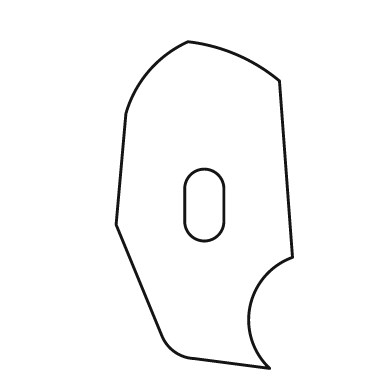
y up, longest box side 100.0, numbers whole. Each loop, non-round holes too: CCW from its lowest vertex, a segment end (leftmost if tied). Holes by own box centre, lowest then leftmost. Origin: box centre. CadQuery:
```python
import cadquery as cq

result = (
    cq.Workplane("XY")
    .moveTo(20.0, -50.0)
    .threePointArc((14.0, -31.0), (27.0, -16.0))
    .lineTo(23.0, 38.0)
    .threePointArc((10.0, 46.0), (-5.0, 50.0))
    .threePointArc((-17.0, 41.0), (-24.0, 28.0))
    .lineTo(-27.0, -6.0)
    .lineTo(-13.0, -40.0)
    .threePointArc((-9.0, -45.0), (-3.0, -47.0))
    .close()
    .moveTo(-6.0, -5.0)
    .threePointArc((0.0, -11.0), (6.0, -5.0))
    .lineTo(6.0, 5.0)
    .threePointArc((0.0, 11.0), (-6.0, 5.0))
    .close()
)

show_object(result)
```